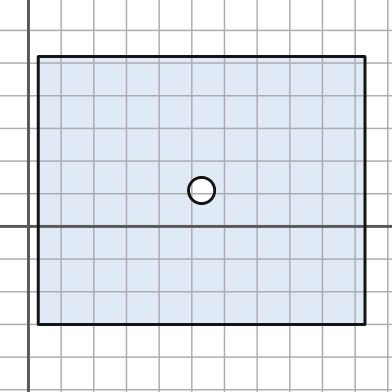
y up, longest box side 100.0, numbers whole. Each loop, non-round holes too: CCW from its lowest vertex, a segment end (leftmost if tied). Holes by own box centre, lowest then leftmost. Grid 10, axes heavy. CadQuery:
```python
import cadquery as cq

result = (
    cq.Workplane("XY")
    .moveTo(3.0, -30.0)
    .lineTo(103.0, -30.0)
    .lineTo(103.0, 52.0)
    .lineTo(3.0, 52.0)
    .close()
    .moveTo(53.0, 11.0)
    .circle(4.0)
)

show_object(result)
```